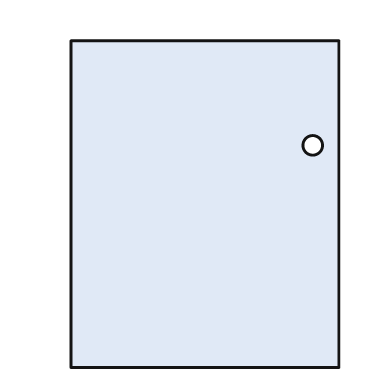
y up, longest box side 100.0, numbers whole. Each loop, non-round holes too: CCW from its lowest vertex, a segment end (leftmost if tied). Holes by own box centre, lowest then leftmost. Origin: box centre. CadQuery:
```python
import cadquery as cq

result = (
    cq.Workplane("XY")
    .moveTo(-41.0, -50.0)
    .lineTo(41.0, -50.0)
    .lineTo(41.0, 50.0)
    .lineTo(-41.0, 50.0)
    .close()
    .moveTo(33.0, 18.0)
    .circle(3.0)
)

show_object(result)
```